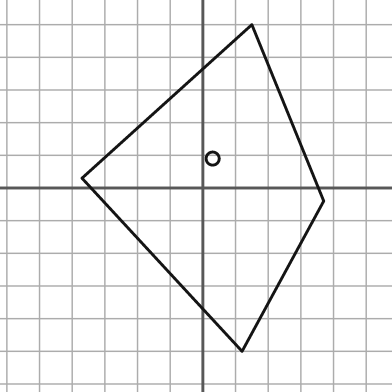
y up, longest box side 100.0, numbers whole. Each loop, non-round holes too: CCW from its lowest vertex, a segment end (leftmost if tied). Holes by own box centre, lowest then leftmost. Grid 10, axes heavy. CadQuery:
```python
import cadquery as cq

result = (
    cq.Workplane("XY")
    .moveTo(12.0, -50.0)
    .lineTo(37.0, -4.0)
    .lineTo(15.0, 50.0)
    .lineTo(-37.0, 3.0)
    .close()
    .moveTo(3.0, 9.0)
    .circle(2.0)
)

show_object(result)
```